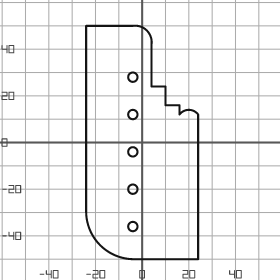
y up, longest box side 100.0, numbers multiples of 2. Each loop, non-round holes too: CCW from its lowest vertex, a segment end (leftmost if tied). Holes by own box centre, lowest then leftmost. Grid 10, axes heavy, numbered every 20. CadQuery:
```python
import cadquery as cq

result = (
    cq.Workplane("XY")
    .moveTo(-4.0, -50.0)
    .lineTo(24.0, -50.0)
    .lineTo(24.0, 12.0)
    .threePointArc((20.0, 14.0), (16.0, 12.0))
    .lineTo(16.0, 16.0)
    .lineTo(10.0, 16.0)
    .lineTo(10.0, 24.0)
    .lineTo(4.0, 24.0)
    .lineTo(4.0, 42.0)
    .threePointArc((2.0, 48.0), (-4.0, 50.0))
    .lineTo(-24.0, 50.0)
    .lineTo(-24.0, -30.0)
    .threePointArc((-18.0, -44.0), (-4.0, -50.0))
    .close()
    .moveTo(-4.0, -36.0)
    .circle(2.0)
    .moveTo(-4.0, -20.0)
    .circle(2.0)
    .moveTo(-4.0, -4.0)
    .circle(2.0)
    .moveTo(-4.0, 12.0)
    .circle(2.0)
    .moveTo(-4.0, 28.0)
    .circle(2.0)
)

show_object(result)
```